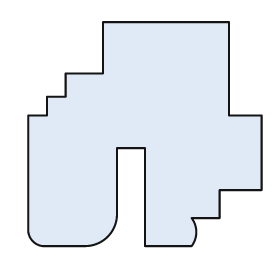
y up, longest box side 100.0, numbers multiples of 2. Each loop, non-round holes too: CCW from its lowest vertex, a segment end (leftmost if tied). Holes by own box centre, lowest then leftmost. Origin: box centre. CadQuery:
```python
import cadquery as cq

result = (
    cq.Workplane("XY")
    .moveTo(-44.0, -48.0)
    .lineTo(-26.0, -48.0)
    .threePointArc((-16.0, -44.0), (-12.0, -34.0))
    .lineTo(-12.0, -6.0)
    .lineTo(0.0, -6.0)
    .lineTo(0.0, -48.0)
    .lineTo(20.0, -48.0)
    .threePointArc((22.0, -42.0), (20.0, -36.0))
    .lineTo(32.0, -36.0)
    .lineTo(32.0, -24.0)
    .lineTo(50.0, -24.0)
    .lineTo(50.0, 8.0)
    .lineTo(36.0, 8.0)
    .lineTo(36.0, 48.0)
    .lineTo(-18.0, 48.0)
    .lineTo(-18.0, 26.0)
    .lineTo(-34.0, 26.0)
    .lineTo(-34.0, 16.0)
    .lineTo(-42.0, 16.0)
    .lineTo(-42.0, 8.0)
    .lineTo(-50.0, 8.0)
    .lineTo(-50.0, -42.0)
    .threePointArc((-48.0, -46.0), (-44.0, -48.0))
    .close()
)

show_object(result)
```